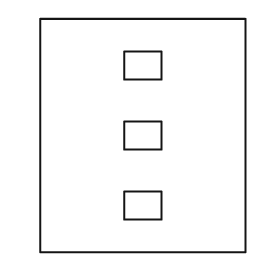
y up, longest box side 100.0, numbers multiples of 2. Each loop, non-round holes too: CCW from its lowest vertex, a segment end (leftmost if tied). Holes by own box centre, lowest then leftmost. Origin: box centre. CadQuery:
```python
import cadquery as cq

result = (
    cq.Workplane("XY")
    .moveTo(-44.0, -50.0)
    .lineTo(44.0, -50.0)
    .lineTo(44.0, 50.0)
    .lineTo(-44.0, 50.0)
    .close()
    .moveTo(-8.0, -36.0)
    .lineTo(8.0, -36.0)
    .lineTo(8.0, -24.0)
    .lineTo(-8.0, -24.0)
    .close()
    .moveTo(-8.0, -6.0)
    .lineTo(8.0, -6.0)
    .lineTo(8.0, 6.0)
    .lineTo(-8.0, 6.0)
    .close()
    .moveTo(-8.0, 24.0)
    .lineTo(8.0, 24.0)
    .lineTo(8.0, 36.0)
    .lineTo(-8.0, 36.0)
    .close()
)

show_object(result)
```